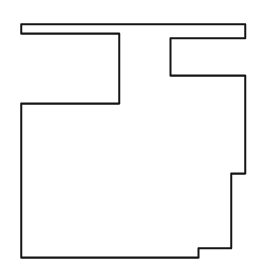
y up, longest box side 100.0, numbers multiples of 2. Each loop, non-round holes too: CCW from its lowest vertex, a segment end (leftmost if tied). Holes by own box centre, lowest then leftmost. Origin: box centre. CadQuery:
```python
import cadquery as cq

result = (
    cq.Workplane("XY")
    .moveTo(-48.0, -50.0)
    .lineTo(28.0, -50.0)
    .lineTo(28.0, -46.0)
    .lineTo(42.0, -46.0)
    .lineTo(42.0, -14.0)
    .lineTo(48.0, -14.0)
    .lineTo(48.0, 28.0)
    .lineTo(16.0, 28.0)
    .lineTo(16.0, 44.0)
    .lineTo(48.0, 44.0)
    .lineTo(48.0, 50.0)
    .lineTo(-48.0, 50.0)
    .lineTo(-48.0, 46.0)
    .lineTo(-6.0, 46.0)
    .lineTo(-6.0, 16.0)
    .lineTo(-48.0, 16.0)
    .close()
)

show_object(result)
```